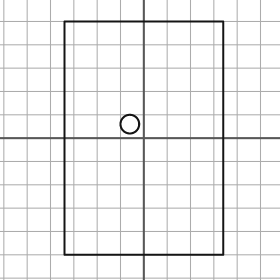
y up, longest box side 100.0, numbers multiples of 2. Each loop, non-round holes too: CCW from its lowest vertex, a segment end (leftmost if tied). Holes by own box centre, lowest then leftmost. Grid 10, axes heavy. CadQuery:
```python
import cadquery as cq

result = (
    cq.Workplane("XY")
    .moveTo(-34.0, -50.0)
    .lineTo(34.0, -50.0)
    .lineTo(34.0, 50.0)
    .lineTo(-34.0, 50.0)
    .close()
    .moveTo(-6.0, 6.0)
    .circle(4.0)
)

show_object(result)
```